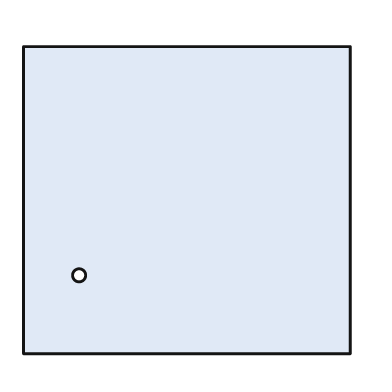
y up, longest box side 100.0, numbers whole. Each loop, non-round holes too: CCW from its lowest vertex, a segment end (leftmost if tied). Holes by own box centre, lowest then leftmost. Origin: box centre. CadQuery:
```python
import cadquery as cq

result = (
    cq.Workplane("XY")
    .moveTo(-50.0, -47.0)
    .lineTo(50.0, -47.0)
    .lineTo(50.0, 47.0)
    .lineTo(-50.0, 47.0)
    .close()
    .moveTo(-33.0, -23.0)
    .circle(2.0)
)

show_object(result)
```